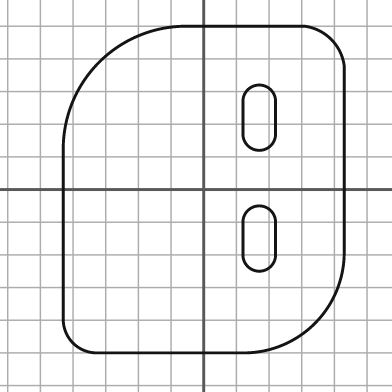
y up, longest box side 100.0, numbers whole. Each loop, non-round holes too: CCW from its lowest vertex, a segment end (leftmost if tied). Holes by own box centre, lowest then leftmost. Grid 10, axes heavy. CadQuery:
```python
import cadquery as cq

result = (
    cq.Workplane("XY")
    .moveTo(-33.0, -50.0)
    .lineTo(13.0, -50.0)
    .threePointArc((34.0, -41.0), (43.0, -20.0))
    .lineTo(43.0, 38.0)
    .threePointArc((39.0, 46.0), (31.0, 50.0))
    .lineTo(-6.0, 50.0)
    .threePointArc((-32.0, 39.0), (-43.0, 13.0))
    .lineTo(-43.0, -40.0)
    .threePointArc((-40.0, -47.0), (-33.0, -50.0))
    .close()
    .moveTo(12.0, -20.0)
    .threePointArc((17.0, -25.0), (22.0, -20.0))
    .lineTo(22.0, -10.0)
    .threePointArc((17.0, -5.0), (12.0, -10.0))
    .close()
    .moveTo(12.0, 17.0)
    .threePointArc((17.0, 12.0), (22.0, 17.0))
    .lineTo(22.0, 27.0)
    .threePointArc((17.0, 32.0), (12.0, 27.0))
    .close()
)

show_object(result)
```